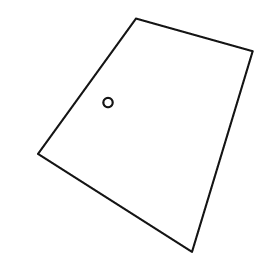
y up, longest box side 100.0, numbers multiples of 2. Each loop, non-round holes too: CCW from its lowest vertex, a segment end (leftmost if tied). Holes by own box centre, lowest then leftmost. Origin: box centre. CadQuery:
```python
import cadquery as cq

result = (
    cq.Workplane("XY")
    .moveTo(20.0, -50.0)
    .lineTo(46.0, 36.0)
    .lineTo(-4.0, 50.0)
    .lineTo(-46.0, -8.0)
    .close()
    .moveTo(-16.0, 14.0)
    .circle(2.0)
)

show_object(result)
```